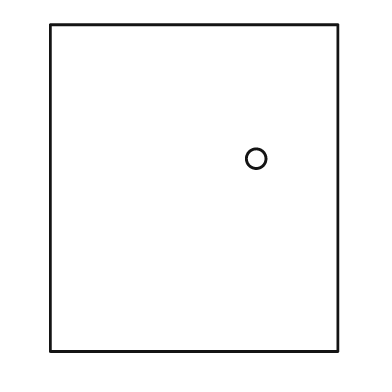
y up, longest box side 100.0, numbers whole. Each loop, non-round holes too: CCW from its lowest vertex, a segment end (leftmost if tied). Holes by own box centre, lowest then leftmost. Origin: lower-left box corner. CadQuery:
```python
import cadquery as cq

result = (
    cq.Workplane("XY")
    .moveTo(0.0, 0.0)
    .lineTo(88.0, 0.0)
    .lineTo(88.0, 100.0)
    .lineTo(0.0, 100.0)
    .close()
    .moveTo(63.0, 59.0)
    .circle(3.0)
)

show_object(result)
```